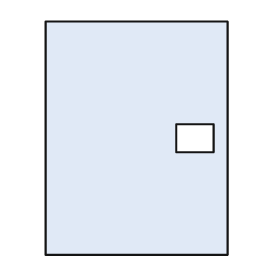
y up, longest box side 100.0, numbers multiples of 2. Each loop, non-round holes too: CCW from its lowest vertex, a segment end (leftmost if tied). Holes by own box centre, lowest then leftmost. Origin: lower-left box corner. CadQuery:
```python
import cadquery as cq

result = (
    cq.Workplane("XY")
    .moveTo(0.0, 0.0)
    .lineTo(78.0, 0.0)
    .lineTo(78.0, 100.0)
    .lineTo(0.0, 100.0)
    .close()
    .moveTo(56.0, 44.0)
    .lineTo(72.0, 44.0)
    .lineTo(72.0, 56.0)
    .lineTo(56.0, 56.0)
    .close()
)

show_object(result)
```